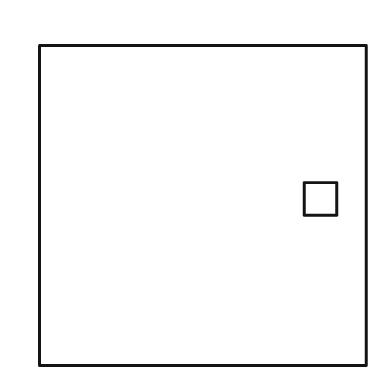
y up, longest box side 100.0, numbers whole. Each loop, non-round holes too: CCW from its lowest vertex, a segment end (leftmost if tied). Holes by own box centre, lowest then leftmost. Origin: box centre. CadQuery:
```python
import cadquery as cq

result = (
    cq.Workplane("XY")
    .moveTo(-50.0, -49.0)
    .lineTo(50.0, -49.0)
    .lineTo(50.0, 49.0)
    .lineTo(-50.0, 49.0)
    .close()
    .moveTo(31.0, -3.0)
    .lineTo(41.0, -3.0)
    .lineTo(41.0, 7.0)
    .lineTo(31.0, 7.0)
    .close()
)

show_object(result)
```